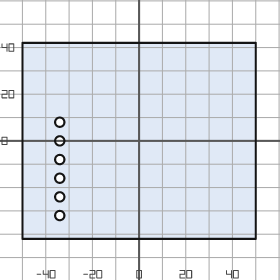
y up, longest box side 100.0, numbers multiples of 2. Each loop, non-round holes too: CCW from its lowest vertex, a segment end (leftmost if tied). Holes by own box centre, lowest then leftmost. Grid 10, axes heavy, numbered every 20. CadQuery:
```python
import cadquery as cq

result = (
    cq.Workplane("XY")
    .moveTo(-50.0, -42.0)
    .lineTo(50.0, -42.0)
    .lineTo(50.0, 42.0)
    .lineTo(-50.0, 42.0)
    .close()
    .moveTo(-34.0, -32.0)
    .circle(2.0)
    .moveTo(-34.0, -24.0)
    .circle(2.0)
    .moveTo(-34.0, -16.0)
    .circle(2.0)
    .moveTo(-34.0, -8.0)
    .circle(2.0)
    .moveTo(-34.0, 0.0)
    .circle(2.0)
    .moveTo(-34.0, 8.0)
    .circle(2.0)
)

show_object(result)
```